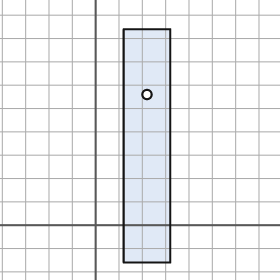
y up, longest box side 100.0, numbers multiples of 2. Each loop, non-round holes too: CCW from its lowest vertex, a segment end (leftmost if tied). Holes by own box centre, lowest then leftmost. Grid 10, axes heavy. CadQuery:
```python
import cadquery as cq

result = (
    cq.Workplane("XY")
    .moveTo(12.0, -16.0)
    .lineTo(32.0, -16.0)
    .lineTo(32.0, 84.0)
    .lineTo(12.0, 84.0)
    .close()
    .moveTo(22.0, 56.0)
    .circle(2.0)
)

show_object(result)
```